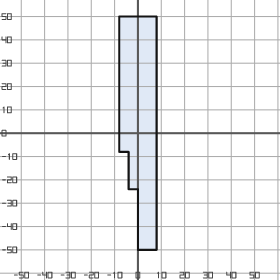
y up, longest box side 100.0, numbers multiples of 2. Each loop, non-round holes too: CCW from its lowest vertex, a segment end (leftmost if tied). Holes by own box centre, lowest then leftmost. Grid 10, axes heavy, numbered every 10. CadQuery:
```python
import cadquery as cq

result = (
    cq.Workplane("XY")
    .moveTo(0.0, -50.0)
    .lineTo(8.0, -50.0)
    .lineTo(8.0, 50.0)
    .lineTo(-8.0, 50.0)
    .lineTo(-8.0, -8.0)
    .lineTo(-4.0, -8.0)
    .lineTo(-4.0, -24.0)
    .lineTo(0.0, -24.0)
    .close()
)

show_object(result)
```